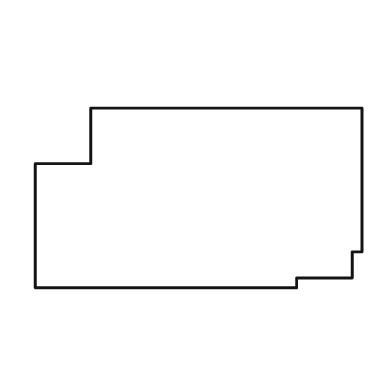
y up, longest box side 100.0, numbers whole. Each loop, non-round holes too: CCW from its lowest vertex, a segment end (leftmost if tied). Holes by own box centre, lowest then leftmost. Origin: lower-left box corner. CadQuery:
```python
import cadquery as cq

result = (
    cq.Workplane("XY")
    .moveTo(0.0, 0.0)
    .lineTo(80.0, 0.0)
    .lineTo(80.0, 3.0)
    .lineTo(97.0, 3.0)
    .lineTo(97.0, 11.0)
    .lineTo(100.0, 11.0)
    .lineTo(100.0, 55.0)
    .lineTo(17.0, 55.0)
    .lineTo(17.0, 38.0)
    .lineTo(0.0, 38.0)
    .close()
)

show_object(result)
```